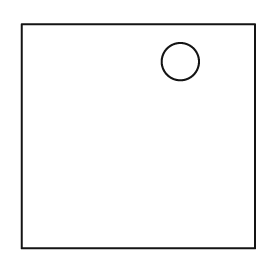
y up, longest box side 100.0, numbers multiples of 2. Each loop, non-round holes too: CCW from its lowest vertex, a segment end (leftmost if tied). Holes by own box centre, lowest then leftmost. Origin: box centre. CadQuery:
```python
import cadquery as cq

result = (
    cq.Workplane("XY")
    .moveTo(-50.0, -48.0)
    .lineTo(50.0, -48.0)
    .lineTo(50.0, 48.0)
    .lineTo(-50.0, 48.0)
    .close()
    .moveTo(18.0, 32.0)
    .circle(8.0)
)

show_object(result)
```